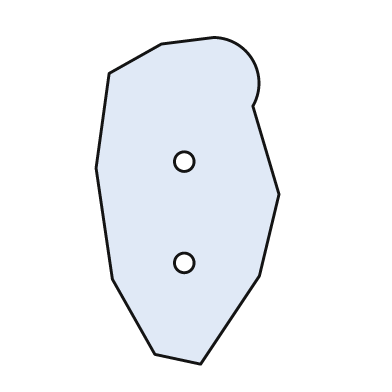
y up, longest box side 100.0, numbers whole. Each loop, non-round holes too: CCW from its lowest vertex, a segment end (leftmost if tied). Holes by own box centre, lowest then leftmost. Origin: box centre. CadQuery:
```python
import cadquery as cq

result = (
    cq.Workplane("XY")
    .moveTo(4.0, -50.0)
    .lineTo(22.0, -23.0)
    .lineTo(28.0, 2.0)
    .lineTo(20.0, 29.0)
    .threePointArc((20.0, 43.0), (8.0, 50.0))
    .lineTo(-8.0, 48.0)
    .lineTo(-24.0, 39.0)
    .lineTo(-28.0, 10.0)
    .lineTo(-23.0, -24.0)
    .lineTo(-10.0, -47.0)
    .close()
    .moveTo(-1.0, -19.0)
    .circle(3.0)
    .moveTo(-1.0, 12.0)
    .circle(3.0)
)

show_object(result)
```